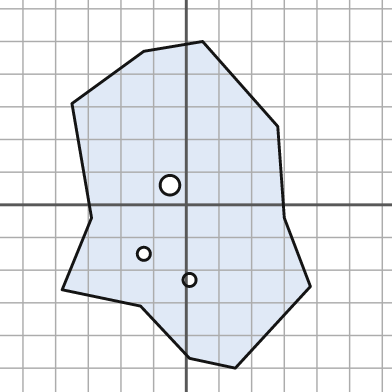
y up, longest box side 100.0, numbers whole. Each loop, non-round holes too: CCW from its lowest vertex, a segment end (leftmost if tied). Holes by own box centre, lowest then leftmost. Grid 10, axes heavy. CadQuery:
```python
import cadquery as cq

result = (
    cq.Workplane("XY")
    .moveTo(15.0, -50.0)
    .lineTo(38.0, -25.0)
    .lineTo(30.0, -4.0)
    .lineTo(28.0, 24.0)
    .lineTo(5.0, 50.0)
    .lineTo(-13.0, 47.0)
    .lineTo(-35.0, 31.0)
    .lineTo(-29.0, -4.0)
    .lineTo(-38.0, -26.0)
    .lineTo(-14.0, -31.0)
    .lineTo(1.0, -47.0)
    .close()
    .moveTo(1.0, -23.0)
    .circle(2.0)
    .moveTo(-13.0, -15.0)
    .circle(2.0)
    .moveTo(-5.0, 6.0)
    .circle(3.0)
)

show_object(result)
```